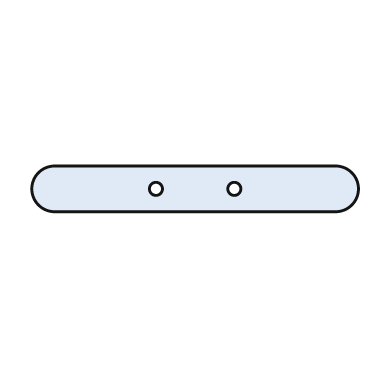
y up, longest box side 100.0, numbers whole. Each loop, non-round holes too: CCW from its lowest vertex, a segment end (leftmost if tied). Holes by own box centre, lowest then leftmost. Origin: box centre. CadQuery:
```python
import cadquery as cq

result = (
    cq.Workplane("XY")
    .moveTo(-43.0, -7.0)
    .lineTo(43.0, -7.0)
    .threePointArc((50.0, 0.0), (43.0, 7.0))
    .lineTo(-43.0, 7.0)
    .threePointArc((-50.0, 0.0), (-43.0, -7.0))
    .close()
    .moveTo(-12.0, 0.0)
    .circle(2.0)
    .moveTo(12.0, 0.0)
    .circle(2.0)
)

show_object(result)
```